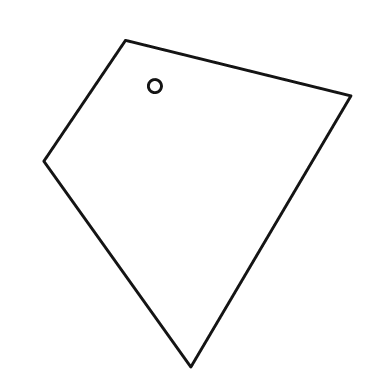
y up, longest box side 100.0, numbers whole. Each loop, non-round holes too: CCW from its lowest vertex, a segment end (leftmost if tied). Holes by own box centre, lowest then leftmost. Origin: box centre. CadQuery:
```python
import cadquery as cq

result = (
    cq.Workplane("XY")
    .moveTo(-2.0, -50.0)
    .lineTo(47.0, 33.0)
    .lineTo(-22.0, 50.0)
    .lineTo(-47.0, 13.0)
    .close()
    .moveTo(-13.0, 36.0)
    .circle(2.0)
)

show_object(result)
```